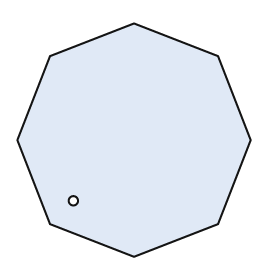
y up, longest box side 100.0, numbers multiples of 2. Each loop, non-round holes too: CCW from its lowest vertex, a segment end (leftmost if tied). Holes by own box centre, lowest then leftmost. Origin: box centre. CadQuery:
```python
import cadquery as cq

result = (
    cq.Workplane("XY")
    .moveTo(0.0, -50.0)
    .lineTo(36.0, -36.0)
    .lineTo(50.0, 0.0)
    .lineTo(36.0, 36.0)
    .lineTo(0.0, 50.0)
    .lineTo(-36.0, 36.0)
    .lineTo(-50.0, 0.0)
    .lineTo(-36.0, -36.0)
    .close()
    .moveTo(-26.0, -26.0)
    .circle(2.0)
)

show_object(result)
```